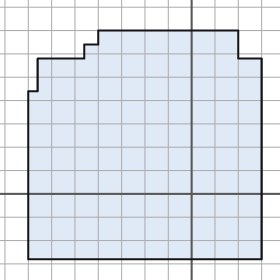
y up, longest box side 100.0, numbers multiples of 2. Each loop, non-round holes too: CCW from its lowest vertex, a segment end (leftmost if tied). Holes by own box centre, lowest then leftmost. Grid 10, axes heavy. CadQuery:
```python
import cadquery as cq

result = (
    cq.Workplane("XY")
    .moveTo(-70.0, -28.0)
    .lineTo(30.0, -28.0)
    .lineTo(30.0, 58.0)
    .lineTo(20.0, 58.0)
    .lineTo(20.0, 70.0)
    .lineTo(-40.0, 70.0)
    .lineTo(-40.0, 64.0)
    .lineTo(-46.0, 64.0)
    .lineTo(-46.0, 58.0)
    .lineTo(-66.0, 58.0)
    .lineTo(-66.0, 44.0)
    .lineTo(-70.0, 44.0)
    .close()
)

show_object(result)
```